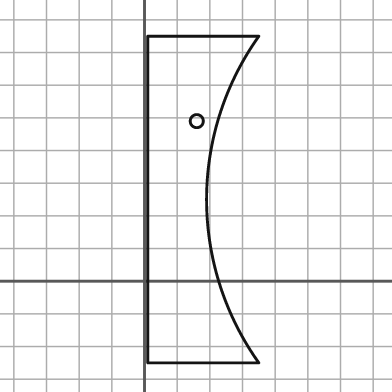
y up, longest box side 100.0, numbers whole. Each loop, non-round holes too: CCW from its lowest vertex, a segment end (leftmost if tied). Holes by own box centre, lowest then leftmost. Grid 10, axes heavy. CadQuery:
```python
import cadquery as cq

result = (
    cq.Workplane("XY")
    .moveTo(1.0, -25.0)
    .lineTo(35.0, -25.0)
    .threePointArc((19.0, 25.0), (35.0, 75.0))
    .lineTo(1.0, 75.0)
    .close()
    .moveTo(16.0, 49.0)
    .circle(2.0)
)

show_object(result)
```